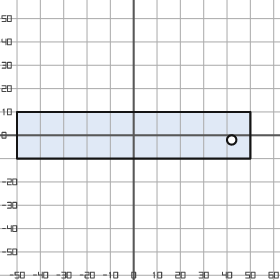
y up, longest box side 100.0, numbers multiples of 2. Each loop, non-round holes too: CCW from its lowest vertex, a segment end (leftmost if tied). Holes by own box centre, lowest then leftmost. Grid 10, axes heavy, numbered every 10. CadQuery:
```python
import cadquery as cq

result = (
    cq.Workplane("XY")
    .moveTo(-50.0, -10.0)
    .lineTo(50.0, -10.0)
    .lineTo(50.0, 10.0)
    .lineTo(-50.0, 10.0)
    .close()
    .moveTo(42.0, -2.0)
    .circle(2.0)
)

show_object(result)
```